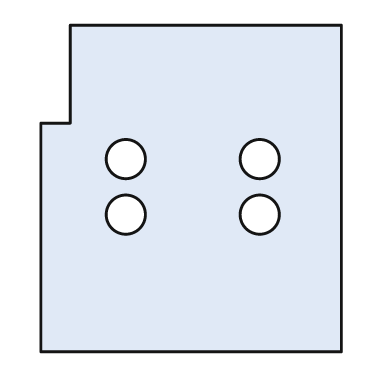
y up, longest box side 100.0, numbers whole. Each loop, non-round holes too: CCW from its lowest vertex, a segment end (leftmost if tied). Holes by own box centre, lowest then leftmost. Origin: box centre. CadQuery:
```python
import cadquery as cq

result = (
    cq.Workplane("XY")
    .moveTo(-46.0, -50.0)
    .lineTo(46.0, -50.0)
    .lineTo(46.0, 50.0)
    .lineTo(-37.0, 50.0)
    .lineTo(-37.0, 20.0)
    .lineTo(-46.0, 20.0)
    .close()
    .moveTo(-20.0, -8.0)
    .circle(6.0)
    .moveTo(21.0, -8.0)
    .circle(6.0)
    .moveTo(-20.0, 9.0)
    .circle(6.0)
    .moveTo(21.0, 9.0)
    .circle(6.0)
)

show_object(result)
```